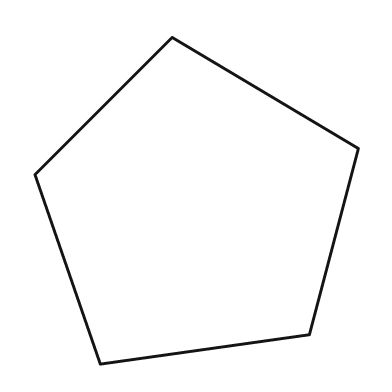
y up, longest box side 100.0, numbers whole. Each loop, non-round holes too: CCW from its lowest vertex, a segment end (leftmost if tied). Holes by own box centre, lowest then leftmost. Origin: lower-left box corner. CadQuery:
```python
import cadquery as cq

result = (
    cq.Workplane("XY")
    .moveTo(20.0, 0.0)
    .lineTo(84.0, 9.0)
    .lineTo(99.0, 66.0)
    .lineTo(42.0, 100.0)
    .lineTo(0.0, 58.0)
    .close()
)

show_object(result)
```